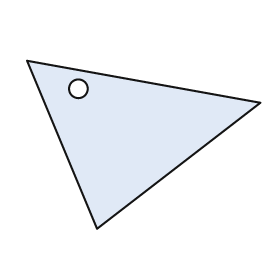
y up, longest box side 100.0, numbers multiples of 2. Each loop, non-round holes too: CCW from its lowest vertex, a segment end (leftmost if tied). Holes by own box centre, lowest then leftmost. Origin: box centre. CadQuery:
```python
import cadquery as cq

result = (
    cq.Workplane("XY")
    .moveTo(-20.0, -36.0)
    .lineTo(50.0, 18.0)
    .lineTo(-50.0, 36.0)
    .close()
    .moveTo(-28.0, 24.0)
    .circle(4.0)
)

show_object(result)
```